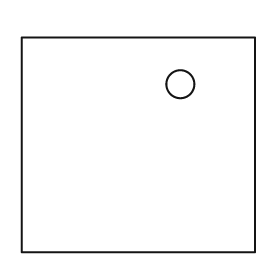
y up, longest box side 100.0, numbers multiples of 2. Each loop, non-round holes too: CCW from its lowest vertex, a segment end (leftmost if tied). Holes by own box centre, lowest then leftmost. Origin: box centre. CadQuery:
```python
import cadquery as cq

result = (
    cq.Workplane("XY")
    .moveTo(-50.0, -46.0)
    .lineTo(50.0, -46.0)
    .lineTo(50.0, 46.0)
    .lineTo(-50.0, 46.0)
    .close()
    .moveTo(18.0, 26.0)
    .circle(6.0)
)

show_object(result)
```